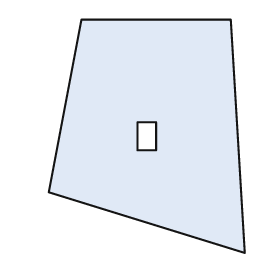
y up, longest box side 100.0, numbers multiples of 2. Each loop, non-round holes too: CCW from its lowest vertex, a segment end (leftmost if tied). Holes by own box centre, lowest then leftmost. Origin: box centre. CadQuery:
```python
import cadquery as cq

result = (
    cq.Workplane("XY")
    .moveTo(42.0, -50.0)
    .lineTo(36.0, 50.0)
    .lineTo(-28.0, 50.0)
    .lineTo(-42.0, -24.0)
    .close()
    .moveTo(-4.0, -6.0)
    .lineTo(4.0, -6.0)
    .lineTo(4.0, 6.0)
    .lineTo(-4.0, 6.0)
    .close()
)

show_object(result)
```